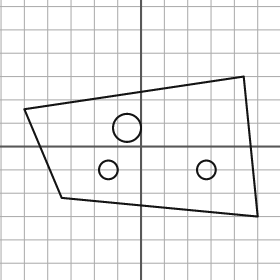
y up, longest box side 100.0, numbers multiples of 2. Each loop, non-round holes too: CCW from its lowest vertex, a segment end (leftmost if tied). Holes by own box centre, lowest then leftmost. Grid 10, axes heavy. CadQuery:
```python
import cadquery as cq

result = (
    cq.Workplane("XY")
    .moveTo(50.0, -30.0)
    .lineTo(44.0, 30.0)
    .lineTo(-50.0, 16.0)
    .lineTo(-34.0, -22.0)
    .close()
    .moveTo(-14.0, -10.0)
    .circle(4.0)
    .moveTo(28.0, -10.0)
    .circle(4.0)
    .moveTo(-6.0, 8.0)
    .circle(6.0)
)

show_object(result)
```